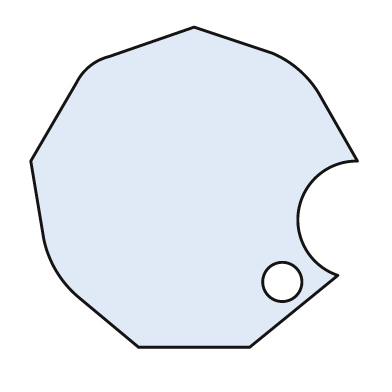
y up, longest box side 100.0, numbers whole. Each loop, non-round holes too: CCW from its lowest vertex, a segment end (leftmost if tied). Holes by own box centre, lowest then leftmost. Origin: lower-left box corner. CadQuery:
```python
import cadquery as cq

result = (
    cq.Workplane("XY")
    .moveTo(33.0, 0.0)
    .lineTo(67.0, 0.0)
    .lineTo(94.0, 22.0)
    .threePointArc((82.0, 42.0), (100.0, 57.0))
    .lineTo(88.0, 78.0)
    .threePointArc((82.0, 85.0), (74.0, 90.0))
    .lineTo(50.0, 98.0)
    .lineTo(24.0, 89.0)
    .threePointArc((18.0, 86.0), (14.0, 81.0))
    .lineTo(0.0, 57.0)
    .lineTo(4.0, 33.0)
    .threePointArc((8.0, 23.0), (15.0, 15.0))
    .close()
    .moveTo(77.0, 20.0)
    .circle(6.0)
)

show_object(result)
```